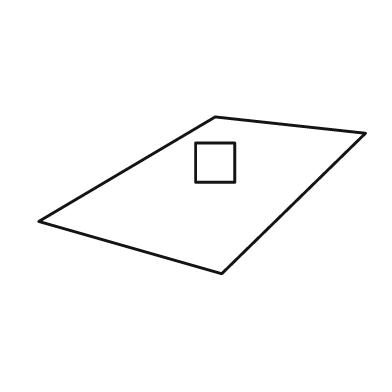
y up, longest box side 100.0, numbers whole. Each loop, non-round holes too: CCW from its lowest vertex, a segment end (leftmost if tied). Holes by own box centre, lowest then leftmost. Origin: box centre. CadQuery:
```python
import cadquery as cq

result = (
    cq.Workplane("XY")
    .moveTo(6.0, -24.0)
    .lineTo(50.0, 19.0)
    .lineTo(4.0, 24.0)
    .lineTo(-50.0, -8.0)
    .close()
    .moveTo(-2.0, 4.0)
    .lineTo(10.0, 4.0)
    .lineTo(10.0, 16.0)
    .lineTo(-2.0, 16.0)
    .close()
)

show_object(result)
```